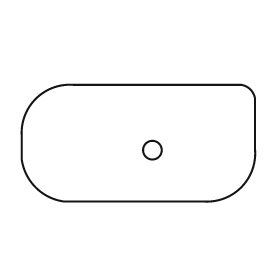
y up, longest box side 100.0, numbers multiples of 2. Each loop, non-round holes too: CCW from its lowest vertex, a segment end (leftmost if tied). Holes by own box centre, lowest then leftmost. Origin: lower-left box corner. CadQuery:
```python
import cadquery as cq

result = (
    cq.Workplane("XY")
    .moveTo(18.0, 0.0)
    .lineTo(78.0, 0.0)
    .threePointArc((94.0, 6.0), (100.0, 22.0))
    .lineTo(100.0, 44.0)
    .threePointArc((98.0, 48.0), (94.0, 50.0))
    .lineTo(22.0, 50.0)
    .threePointArc((6.0, 44.0), (0.0, 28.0))
    .lineTo(0.0, 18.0)
    .threePointArc((6.0, 6.0), (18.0, 0.0))
    .close()
    .moveTo(56.0, 22.0)
    .circle(4.0)
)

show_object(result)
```